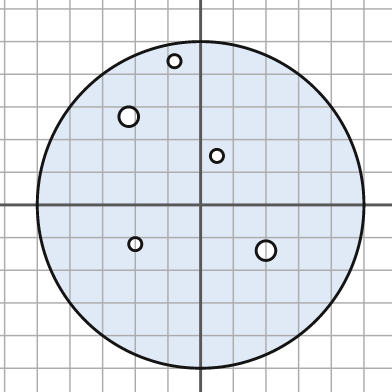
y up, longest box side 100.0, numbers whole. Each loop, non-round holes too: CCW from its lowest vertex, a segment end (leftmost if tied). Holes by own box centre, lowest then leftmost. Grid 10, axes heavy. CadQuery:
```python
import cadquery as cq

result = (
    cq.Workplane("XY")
    .moveTo(0.0, 0.0)
    .circle(50.0)
    .moveTo(20.0, -14.0)
    .circle(3.0)
    .moveTo(-20.0, -12.0)
    .circle(2.0)
    .moveTo(5.0, 15.0)
    .circle(2.0)
    .moveTo(-22.0, 27.0)
    .circle(3.0)
    .moveTo(-8.0, 44.0)
    .circle(2.0)
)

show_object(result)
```